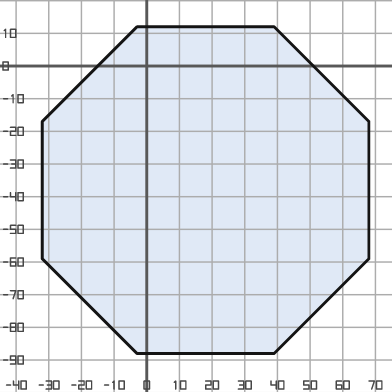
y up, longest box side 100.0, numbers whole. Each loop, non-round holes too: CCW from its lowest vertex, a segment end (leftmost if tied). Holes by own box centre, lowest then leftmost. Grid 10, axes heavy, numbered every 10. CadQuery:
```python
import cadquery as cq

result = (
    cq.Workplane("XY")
    .moveTo(-3.0, -88.0)
    .lineTo(39.0, -88.0)
    .lineTo(68.0, -59.0)
    .lineTo(68.0, -17.0)
    .lineTo(39.0, 12.0)
    .lineTo(-3.0, 12.0)
    .lineTo(-32.0, -17.0)
    .lineTo(-32.0, -59.0)
    .close()
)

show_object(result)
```